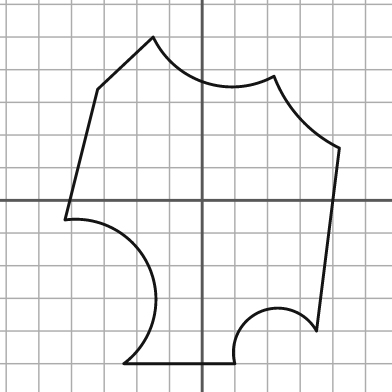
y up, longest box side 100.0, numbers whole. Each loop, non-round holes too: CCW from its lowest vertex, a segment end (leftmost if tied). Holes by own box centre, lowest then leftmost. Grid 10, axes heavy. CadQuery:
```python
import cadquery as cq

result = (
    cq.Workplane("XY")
    .moveTo(-24.0, -50.0)
    .lineTo(10.0, -50.0)
    .threePointArc((18.0, -34.0), (35.0, -40.0))
    .lineTo(42.0, 16.0)
    .threePointArc((30.0, 25.0), (22.0, 38.0))
    .threePointArc((1.0, 36.0), (-15.0, 50.0))
    .lineTo(-32.0, 34.0)
    .lineTo(-42.0, -6.0)
    .threePointArc((-16.0, -21.0), (-24.0, -50.0))
    .close()
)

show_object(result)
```